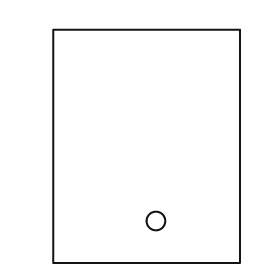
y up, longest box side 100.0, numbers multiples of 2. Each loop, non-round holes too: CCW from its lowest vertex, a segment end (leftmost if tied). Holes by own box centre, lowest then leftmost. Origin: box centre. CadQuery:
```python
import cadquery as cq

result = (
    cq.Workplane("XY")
    .moveTo(-40.0, -50.0)
    .lineTo(40.0, -50.0)
    .lineTo(40.0, 50.0)
    .lineTo(-40.0, 50.0)
    .close()
    .moveTo(4.0, -32.0)
    .circle(4.0)
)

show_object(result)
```